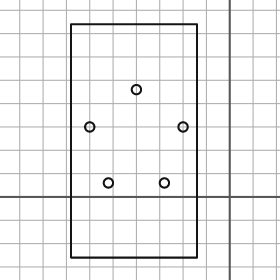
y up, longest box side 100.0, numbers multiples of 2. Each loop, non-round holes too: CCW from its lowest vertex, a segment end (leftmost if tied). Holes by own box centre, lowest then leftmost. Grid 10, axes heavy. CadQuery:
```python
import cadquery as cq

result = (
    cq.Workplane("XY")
    .moveTo(-68.0, -26.0)
    .lineTo(-14.0, -26.0)
    .lineTo(-14.0, 74.0)
    .lineTo(-68.0, 74.0)
    .close()
    .moveTo(-52.0, 6.0)
    .circle(2.0)
    .moveTo(-28.0, 6.0)
    .circle(2.0)
    .moveTo(-60.0, 30.0)
    .circle(2.0)
    .moveTo(-20.0, 30.0)
    .circle(2.0)
    .moveTo(-40.0, 46.0)
    .circle(2.0)
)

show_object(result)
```